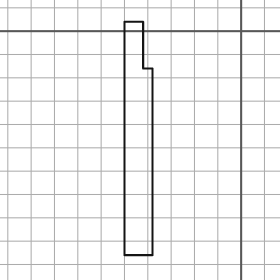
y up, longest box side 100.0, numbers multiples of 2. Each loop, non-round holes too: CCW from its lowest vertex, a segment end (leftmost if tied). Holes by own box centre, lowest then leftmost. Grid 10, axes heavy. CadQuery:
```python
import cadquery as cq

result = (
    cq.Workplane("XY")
    .moveTo(-50.0, -96.0)
    .lineTo(-38.0, -96.0)
    .lineTo(-38.0, -16.0)
    .lineTo(-42.0, -16.0)
    .lineTo(-42.0, 4.0)
    .lineTo(-50.0, 4.0)
    .close()
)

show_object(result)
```